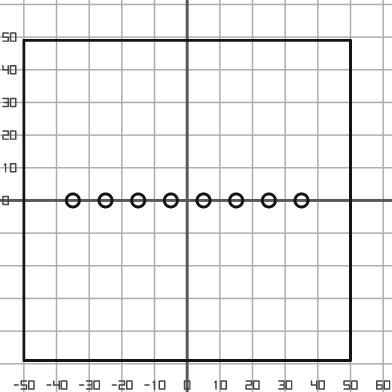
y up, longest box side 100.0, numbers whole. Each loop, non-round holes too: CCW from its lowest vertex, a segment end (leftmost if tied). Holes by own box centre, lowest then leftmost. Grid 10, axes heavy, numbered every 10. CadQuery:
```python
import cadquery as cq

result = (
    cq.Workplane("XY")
    .moveTo(-50.0, -49.0)
    .lineTo(50.0, -49.0)
    .lineTo(50.0, 49.0)
    .lineTo(-50.0, 49.0)
    .close()
    .moveTo(-35.0, 0.0)
    .circle(2.0)
    .moveTo(-25.0, 0.0)
    .circle(2.0)
    .moveTo(-15.0, 0.0)
    .circle(2.0)
    .moveTo(-5.0, 0.0)
    .circle(2.0)
    .moveTo(5.0, 0.0)
    .circle(2.0)
    .moveTo(15.0, 0.0)
    .circle(2.0)
    .moveTo(25.0, 0.0)
    .circle(2.0)
    .moveTo(35.0, 0.0)
    .circle(2.0)
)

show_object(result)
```